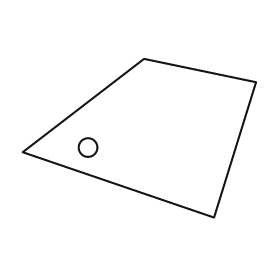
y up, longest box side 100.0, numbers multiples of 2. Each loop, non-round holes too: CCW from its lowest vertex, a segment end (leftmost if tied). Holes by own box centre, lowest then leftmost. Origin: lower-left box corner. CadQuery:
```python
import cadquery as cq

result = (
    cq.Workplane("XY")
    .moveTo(82.0, 0.0)
    .lineTo(100.0, 58.0)
    .lineTo(52.0, 68.0)
    .lineTo(0.0, 28.0)
    .close()
    .moveTo(28.0, 30.0)
    .circle(4.0)
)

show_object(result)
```